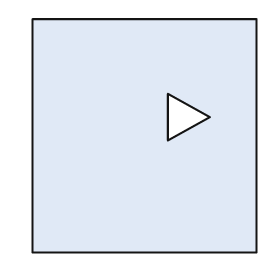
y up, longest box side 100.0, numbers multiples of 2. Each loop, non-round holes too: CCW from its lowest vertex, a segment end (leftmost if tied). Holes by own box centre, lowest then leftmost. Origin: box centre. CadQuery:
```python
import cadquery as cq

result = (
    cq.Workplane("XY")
    .moveTo(-48.0, -50.0)
    .lineTo(48.0, -50.0)
    .lineTo(48.0, 50.0)
    .lineTo(-48.0, 50.0)
    .close()
    .moveTo(10.0, -2.0)
    .lineTo(28.0, 8.0)
    .lineTo(10.0, 18.0)
    .close()
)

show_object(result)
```